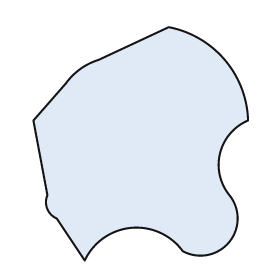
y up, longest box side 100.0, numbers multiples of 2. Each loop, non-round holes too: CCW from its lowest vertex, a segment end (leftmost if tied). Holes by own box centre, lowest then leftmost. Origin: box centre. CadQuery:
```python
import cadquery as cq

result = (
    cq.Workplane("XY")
    .moveTo(-24.0, -50.0)
    .threePointArc((-4.0, -36.0), (18.0, -46.0))
    .threePointArc((38.0, -42.0), (38.0, -22.0))
    .threePointArc((34.0, -4.0), (46.0, 10.0))
    .threePointArc((36.0, 36.0), (12.0, 50.0))
    .lineTo(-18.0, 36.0)
    .threePointArc((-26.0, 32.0), (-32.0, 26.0))
    .lineTo(-46.0, 10.0)
    .lineTo(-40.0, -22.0)
    .threePointArc((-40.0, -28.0), (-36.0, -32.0))
    .close()
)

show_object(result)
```